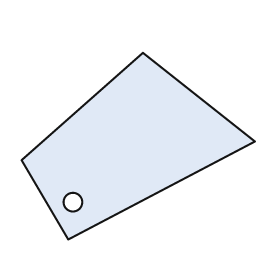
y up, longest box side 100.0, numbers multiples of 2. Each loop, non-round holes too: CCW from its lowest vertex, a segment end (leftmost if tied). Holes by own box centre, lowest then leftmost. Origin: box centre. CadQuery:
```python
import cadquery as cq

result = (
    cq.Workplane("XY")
    .moveTo(-30.0, -40.0)
    .lineTo(50.0, 2.0)
    .lineTo(2.0, 40.0)
    .lineTo(-50.0, -6.0)
    .close()
    .moveTo(-28.0, -24.0)
    .circle(4.0)
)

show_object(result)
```